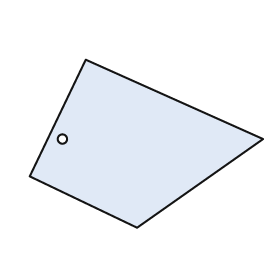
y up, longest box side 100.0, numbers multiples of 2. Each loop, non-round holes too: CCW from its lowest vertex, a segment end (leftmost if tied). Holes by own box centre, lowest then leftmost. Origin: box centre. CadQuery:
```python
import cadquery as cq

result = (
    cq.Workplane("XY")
    .moveTo(-4.0, -36.0)
    .lineTo(50.0, 2.0)
    .lineTo(-26.0, 36.0)
    .lineTo(-50.0, -14.0)
    .close()
    .moveTo(-36.0, 2.0)
    .circle(2.0)
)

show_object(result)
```